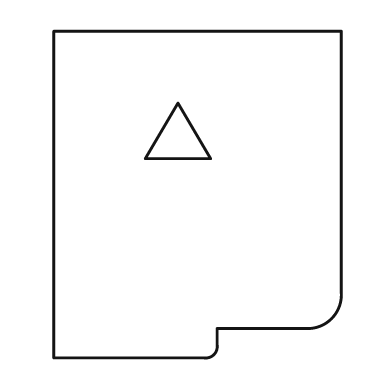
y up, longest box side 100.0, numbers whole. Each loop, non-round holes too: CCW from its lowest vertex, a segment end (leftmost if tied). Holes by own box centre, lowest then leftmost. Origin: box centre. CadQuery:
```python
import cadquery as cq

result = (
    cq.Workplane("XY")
    .moveTo(-44.0, -50.0)
    .lineTo(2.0, -50.0)
    .threePointArc((5.0, -49.0), (6.0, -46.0))
    .lineTo(6.0, -41.0)
    .lineTo(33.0, -41.0)
    .threePointArc((41.0, -38.0), (44.0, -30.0))
    .lineTo(44.0, 50.0)
    .lineTo(-44.0, 50.0)
    .close()
    .moveTo(-16.0, 11.0)
    .lineTo(4.0, 11.0)
    .lineTo(-6.0, 28.0)
    .close()
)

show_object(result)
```